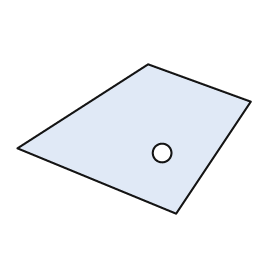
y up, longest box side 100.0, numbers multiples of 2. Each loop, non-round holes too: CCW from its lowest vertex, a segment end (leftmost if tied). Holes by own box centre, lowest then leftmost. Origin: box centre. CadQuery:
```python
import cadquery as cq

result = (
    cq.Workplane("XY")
    .moveTo(18.0, -32.0)
    .lineTo(50.0, 16.0)
    .lineTo(6.0, 32.0)
    .lineTo(-50.0, -4.0)
    .close()
    .moveTo(12.0, -6.0)
    .circle(4.0)
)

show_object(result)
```